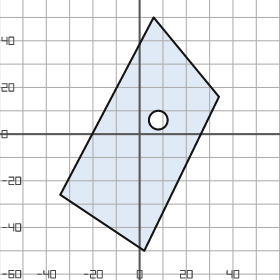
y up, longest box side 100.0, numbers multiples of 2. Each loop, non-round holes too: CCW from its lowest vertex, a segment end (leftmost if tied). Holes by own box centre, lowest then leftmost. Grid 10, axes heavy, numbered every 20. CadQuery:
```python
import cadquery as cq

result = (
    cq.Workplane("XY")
    .moveTo(2.0, -50.0)
    .lineTo(34.0, 16.0)
    .lineTo(6.0, 50.0)
    .lineTo(-34.0, -26.0)
    .close()
    .moveTo(8.0, 6.0)
    .circle(4.0)
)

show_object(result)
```